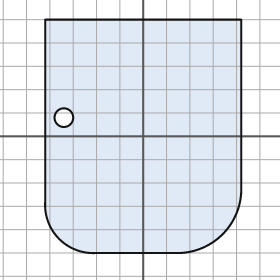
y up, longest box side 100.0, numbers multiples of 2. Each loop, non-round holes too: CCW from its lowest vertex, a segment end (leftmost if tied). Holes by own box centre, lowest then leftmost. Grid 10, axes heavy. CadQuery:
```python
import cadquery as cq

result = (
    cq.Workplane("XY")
    .moveTo(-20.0, -50.0)
    .lineTo(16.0, -50.0)
    .threePointArc((34.0, -42.0), (42.0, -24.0))
    .lineTo(42.0, 50.0)
    .lineTo(-42.0, 50.0)
    .lineTo(-42.0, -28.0)
    .threePointArc((-36.0, -44.0), (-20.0, -50.0))
    .close()
    .moveTo(-34.0, 8.0)
    .circle(4.0)
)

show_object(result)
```